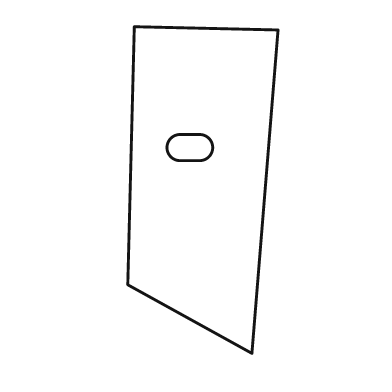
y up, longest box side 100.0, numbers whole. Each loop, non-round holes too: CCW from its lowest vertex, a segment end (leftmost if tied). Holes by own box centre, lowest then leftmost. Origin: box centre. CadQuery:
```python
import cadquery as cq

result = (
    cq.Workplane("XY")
    .moveTo(15.0, -50.0)
    .lineTo(23.0, 49.0)
    .lineTo(-21.0, 50.0)
    .lineTo(-23.0, -29.0)
    .close()
    .moveTo(-7.0, 9.0)
    .lineTo(-1.0, 9.0)
    .threePointArc((3.0, 13.0), (-1.0, 17.0))
    .lineTo(-7.0, 17.0)
    .threePointArc((-11.0, 13.0), (-7.0, 9.0))
    .close()
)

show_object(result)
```